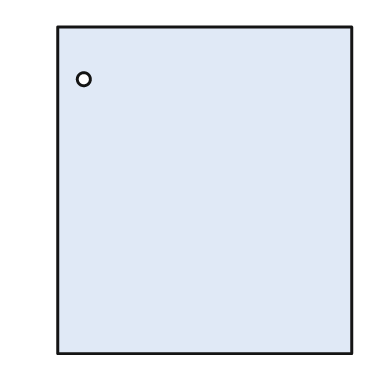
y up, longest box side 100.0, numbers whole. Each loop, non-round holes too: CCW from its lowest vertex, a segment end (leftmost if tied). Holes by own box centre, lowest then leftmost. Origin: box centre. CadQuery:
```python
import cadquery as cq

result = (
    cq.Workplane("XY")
    .moveTo(-45.0, -50.0)
    .lineTo(45.0, -50.0)
    .lineTo(45.0, 50.0)
    .lineTo(-45.0, 50.0)
    .close()
    .moveTo(-37.0, 34.0)
    .circle(2.0)
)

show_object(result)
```